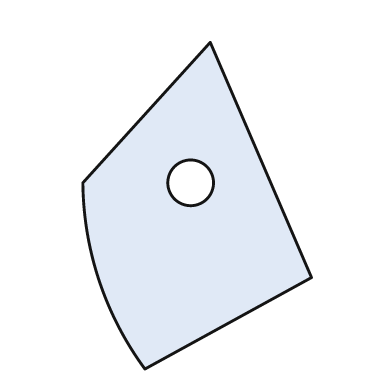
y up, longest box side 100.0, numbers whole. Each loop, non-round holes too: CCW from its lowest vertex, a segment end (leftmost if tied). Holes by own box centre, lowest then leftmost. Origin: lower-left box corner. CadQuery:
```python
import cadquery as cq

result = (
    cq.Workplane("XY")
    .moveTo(19.0, 0.0)
    .lineTo(70.0, 28.0)
    .lineTo(39.0, 100.0)
    .lineTo(0.0, 57.0)
    .threePointArc((5.0, 27.0), (19.0, 0.0))
    .close()
    .moveTo(33.0, 57.0)
    .circle(7.0)
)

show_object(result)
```